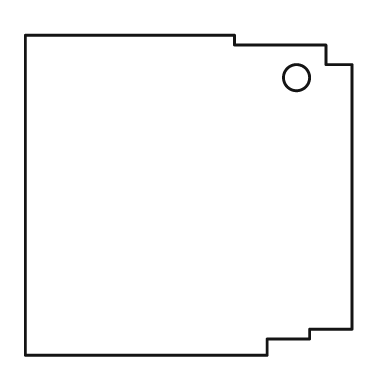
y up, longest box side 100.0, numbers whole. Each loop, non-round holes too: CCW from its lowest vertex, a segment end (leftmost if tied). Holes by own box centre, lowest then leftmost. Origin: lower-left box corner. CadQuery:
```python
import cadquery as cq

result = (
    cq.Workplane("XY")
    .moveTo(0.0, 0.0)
    .lineTo(74.0, 0.0)
    .lineTo(74.0, 5.0)
    .lineTo(87.0, 5.0)
    .lineTo(87.0, 8.0)
    .lineTo(100.0, 8.0)
    .lineTo(100.0, 89.0)
    .lineTo(92.0, 89.0)
    .lineTo(92.0, 95.0)
    .lineTo(64.0, 95.0)
    .lineTo(64.0, 98.0)
    .lineTo(0.0, 98.0)
    .close()
    .moveTo(83.0, 85.0)
    .circle(4.0)
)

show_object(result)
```